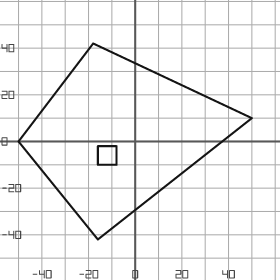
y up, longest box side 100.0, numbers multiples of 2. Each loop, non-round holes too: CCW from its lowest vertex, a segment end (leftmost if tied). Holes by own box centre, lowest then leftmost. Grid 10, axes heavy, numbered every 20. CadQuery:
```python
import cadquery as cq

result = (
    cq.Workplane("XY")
    .moveTo(-16.0, -42.0)
    .lineTo(50.0, 10.0)
    .lineTo(-18.0, 42.0)
    .lineTo(-50.0, 0.0)
    .close()
    .moveTo(-16.0, -10.0)
    .lineTo(-8.0, -10.0)
    .lineTo(-8.0, -2.0)
    .lineTo(-16.0, -2.0)
    .close()
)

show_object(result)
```